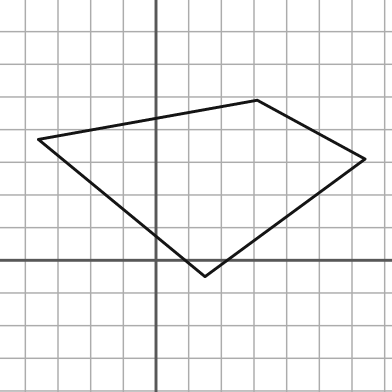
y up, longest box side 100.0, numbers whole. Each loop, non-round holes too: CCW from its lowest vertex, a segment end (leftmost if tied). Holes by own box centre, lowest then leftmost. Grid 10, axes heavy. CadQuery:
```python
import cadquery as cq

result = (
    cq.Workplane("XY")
    .moveTo(15.0, -5.0)
    .lineTo(64.0, 31.0)
    .lineTo(31.0, 49.0)
    .lineTo(-36.0, 37.0)
    .close()
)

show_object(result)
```